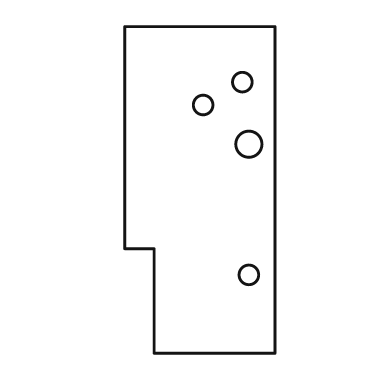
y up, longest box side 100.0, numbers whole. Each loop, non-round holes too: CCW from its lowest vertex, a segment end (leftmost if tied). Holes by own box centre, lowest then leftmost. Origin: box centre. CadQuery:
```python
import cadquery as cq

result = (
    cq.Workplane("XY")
    .moveTo(-14.0, -50.0)
    .lineTo(23.0, -50.0)
    .lineTo(23.0, 50.0)
    .lineTo(-23.0, 50.0)
    .lineTo(-23.0, -18.0)
    .lineTo(-14.0, -18.0)
    .close()
    .moveTo(15.0, -26.0)
    .circle(3.0)
    .moveTo(15.0, 14.0)
    .circle(4.0)
    .moveTo(1.0, 26.0)
    .circle(3.0)
    .moveTo(13.0, 33.0)
    .circle(3.0)
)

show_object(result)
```